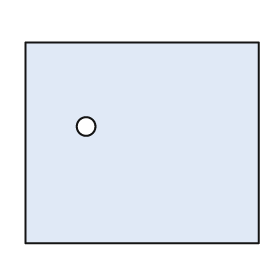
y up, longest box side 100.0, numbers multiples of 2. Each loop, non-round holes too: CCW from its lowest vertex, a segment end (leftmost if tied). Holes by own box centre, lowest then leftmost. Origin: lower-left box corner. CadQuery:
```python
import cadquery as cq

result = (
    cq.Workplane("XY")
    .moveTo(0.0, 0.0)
    .lineTo(100.0, 0.0)
    .lineTo(100.0, 86.0)
    .lineTo(0.0, 86.0)
    .close()
    .moveTo(26.0, 50.0)
    .circle(4.0)
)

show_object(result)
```